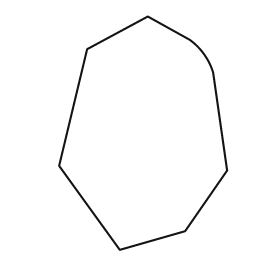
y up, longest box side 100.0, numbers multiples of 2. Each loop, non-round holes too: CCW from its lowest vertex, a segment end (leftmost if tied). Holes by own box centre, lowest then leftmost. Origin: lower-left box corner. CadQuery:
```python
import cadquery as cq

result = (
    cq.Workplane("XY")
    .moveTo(26.0, 0.0)
    .lineTo(54.0, 8.0)
    .lineTo(72.0, 34.0)
    .lineTo(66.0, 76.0)
    .threePointArc((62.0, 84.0), (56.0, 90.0))
    .lineTo(38.0, 100.0)
    .lineTo(12.0, 86.0)
    .lineTo(0.0, 36.0)
    .close()
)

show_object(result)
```